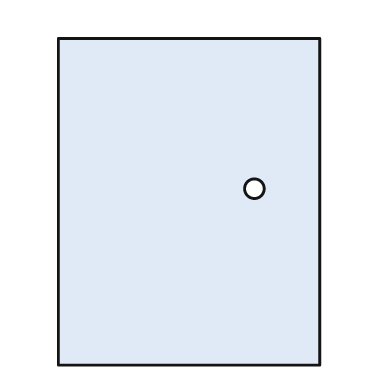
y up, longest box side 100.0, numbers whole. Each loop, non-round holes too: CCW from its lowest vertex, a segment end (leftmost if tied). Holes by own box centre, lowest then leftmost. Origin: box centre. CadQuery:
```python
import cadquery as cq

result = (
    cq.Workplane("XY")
    .moveTo(-40.0, -50.0)
    .lineTo(40.0, -50.0)
    .lineTo(40.0, 50.0)
    .lineTo(-40.0, 50.0)
    .close()
    .moveTo(20.0, 4.0)
    .circle(3.0)
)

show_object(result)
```